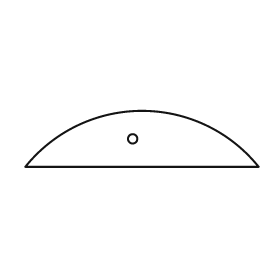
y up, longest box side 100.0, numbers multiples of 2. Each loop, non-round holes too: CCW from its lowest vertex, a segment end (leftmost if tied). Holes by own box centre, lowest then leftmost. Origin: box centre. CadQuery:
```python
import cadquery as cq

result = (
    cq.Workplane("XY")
    .moveTo(-50.0, -12.0)
    .lineTo(50.0, -12.0)
    .threePointArc((0.0, 12.0), (-50.0, -12.0))
    .close()
    .moveTo(-4.0, 0.0)
    .circle(2.0)
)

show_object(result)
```